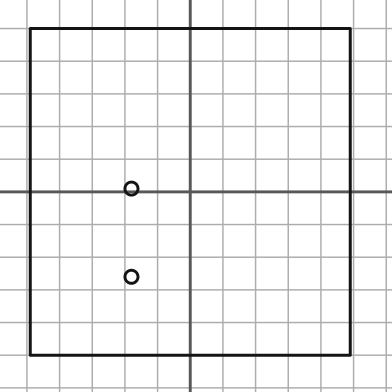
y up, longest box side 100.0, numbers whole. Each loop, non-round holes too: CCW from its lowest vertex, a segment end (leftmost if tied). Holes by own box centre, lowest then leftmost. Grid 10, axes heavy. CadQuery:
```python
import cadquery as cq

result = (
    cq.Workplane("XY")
    .moveTo(-49.0, -50.0)
    .lineTo(49.0, -50.0)
    .lineTo(49.0, 50.0)
    .lineTo(-49.0, 50.0)
    .close()
    .moveTo(-18.0, -26.0)
    .circle(2.0)
    .moveTo(-18.0, 1.0)
    .circle(2.0)
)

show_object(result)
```